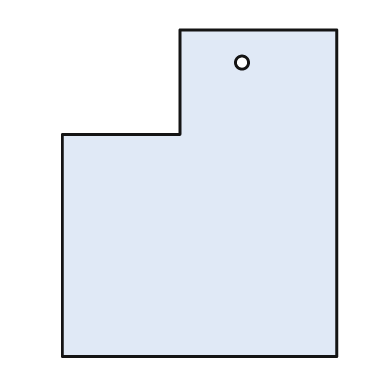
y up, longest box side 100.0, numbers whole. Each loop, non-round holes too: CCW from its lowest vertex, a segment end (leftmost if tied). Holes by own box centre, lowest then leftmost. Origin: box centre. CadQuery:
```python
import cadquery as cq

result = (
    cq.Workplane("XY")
    .moveTo(-42.0, -50.0)
    .lineTo(42.0, -50.0)
    .lineTo(42.0, 50.0)
    .lineTo(-6.0, 50.0)
    .lineTo(-6.0, 18.0)
    .lineTo(-42.0, 18.0)
    .close()
    .moveTo(13.0, 40.0)
    .circle(2.0)
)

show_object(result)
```